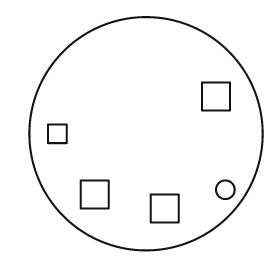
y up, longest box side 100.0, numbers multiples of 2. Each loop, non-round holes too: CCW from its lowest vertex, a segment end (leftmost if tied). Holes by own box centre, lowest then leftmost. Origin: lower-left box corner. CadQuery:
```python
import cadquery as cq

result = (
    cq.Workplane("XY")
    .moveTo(50.0, 50.0)
    .circle(50.0)
    .moveTo(52.0, 12.0)
    .lineTo(64.0, 12.0)
    .lineTo(64.0, 24.0)
    .lineTo(52.0, 24.0)
    .close()
    .moveTo(22.0, 18.0)
    .lineTo(34.0, 18.0)
    .lineTo(34.0, 30.0)
    .lineTo(22.0, 30.0)
    .close()
    .moveTo(84.0, 26.0)
    .circle(4.0)
    .moveTo(8.0, 46.0)
    .lineTo(16.0, 46.0)
    .lineTo(16.0, 54.0)
    .lineTo(8.0, 54.0)
    .close()
    .moveTo(74.0, 60.0)
    .lineTo(86.0, 60.0)
    .lineTo(86.0, 72.0)
    .lineTo(74.0, 72.0)
    .close()
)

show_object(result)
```